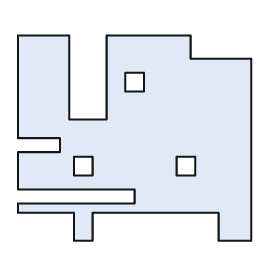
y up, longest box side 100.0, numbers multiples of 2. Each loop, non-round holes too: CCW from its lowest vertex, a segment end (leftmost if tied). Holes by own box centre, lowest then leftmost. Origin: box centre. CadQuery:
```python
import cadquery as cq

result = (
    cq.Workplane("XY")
    .moveTo(-26.0, -44.0)
    .lineTo(-18.0, -44.0)
    .lineTo(-18.0, -32.0)
    .lineTo(36.0, -32.0)
    .lineTo(36.0, -44.0)
    .lineTo(50.0, -44.0)
    .lineTo(50.0, 34.0)
    .lineTo(24.0, 34.0)
    .lineTo(24.0, 44.0)
    .lineTo(-12.0, 44.0)
    .lineTo(-12.0, 8.0)
    .lineTo(-28.0, 8.0)
    .lineTo(-28.0, 44.0)
    .lineTo(-50.0, 44.0)
    .lineTo(-50.0, 0.0)
    .lineTo(-32.0, 0.0)
    .lineTo(-32.0, -6.0)
    .lineTo(-50.0, -6.0)
    .lineTo(-50.0, -22.0)
    .lineTo(0.0, -22.0)
    .lineTo(0.0, -28.0)
    .lineTo(-50.0, -28.0)
    .lineTo(-50.0, -32.0)
    .lineTo(-26.0, -32.0)
    .close()
    .moveTo(-26.0, -16.0)
    .lineTo(-18.0, -16.0)
    .lineTo(-18.0, -8.0)
    .lineTo(-26.0, -8.0)
    .close()
    .moveTo(18.0, -16.0)
    .lineTo(26.0, -16.0)
    .lineTo(26.0, -8.0)
    .lineTo(18.0, -8.0)
    .close()
    .moveTo(-4.0, 20.0)
    .lineTo(4.0, 20.0)
    .lineTo(4.0, 28.0)
    .lineTo(-4.0, 28.0)
    .close()
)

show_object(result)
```